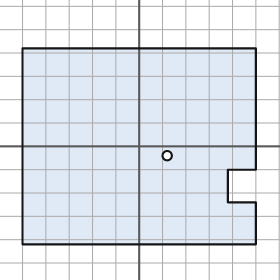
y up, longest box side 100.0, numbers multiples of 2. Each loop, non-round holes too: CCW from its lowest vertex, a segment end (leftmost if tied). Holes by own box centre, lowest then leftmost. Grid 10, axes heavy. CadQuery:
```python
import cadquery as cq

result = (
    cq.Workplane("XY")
    .moveTo(-50.0, -42.0)
    .lineTo(50.0, -42.0)
    .lineTo(50.0, -24.0)
    .lineTo(38.0, -24.0)
    .lineTo(38.0, -10.0)
    .lineTo(50.0, -10.0)
    .lineTo(50.0, 42.0)
    .lineTo(-50.0, 42.0)
    .close()
    .moveTo(12.0, -4.0)
    .circle(2.0)
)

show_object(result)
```